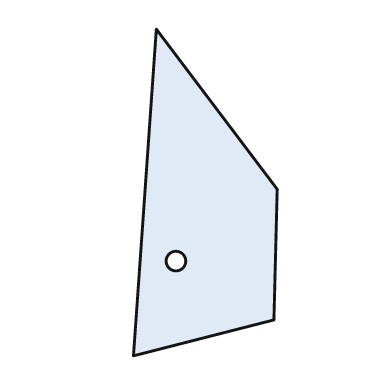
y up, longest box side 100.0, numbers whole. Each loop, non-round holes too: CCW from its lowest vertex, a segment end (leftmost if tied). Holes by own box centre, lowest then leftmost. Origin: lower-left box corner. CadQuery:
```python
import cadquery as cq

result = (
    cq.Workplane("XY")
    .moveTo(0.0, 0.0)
    .lineTo(43.0, 11.0)
    .lineTo(44.0, 51.0)
    .lineTo(7.0, 100.0)
    .close()
    .moveTo(13.0, 29.0)
    .circle(3.0)
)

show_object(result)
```